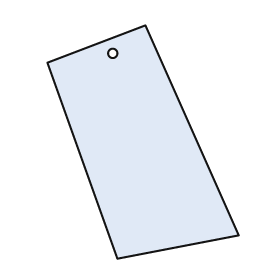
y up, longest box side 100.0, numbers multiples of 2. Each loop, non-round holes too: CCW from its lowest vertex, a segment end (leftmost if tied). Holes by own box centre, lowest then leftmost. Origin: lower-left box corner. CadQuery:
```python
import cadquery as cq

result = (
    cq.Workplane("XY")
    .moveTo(30.0, 0.0)
    .lineTo(82.0, 10.0)
    .lineTo(42.0, 100.0)
    .lineTo(0.0, 84.0)
    .close()
    .moveTo(28.0, 88.0)
    .circle(2.0)
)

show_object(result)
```